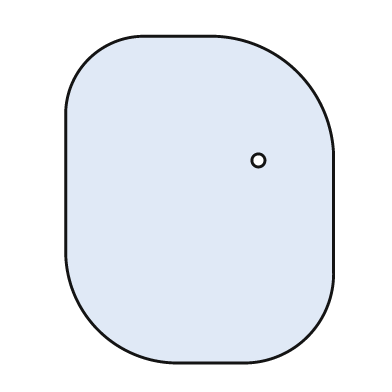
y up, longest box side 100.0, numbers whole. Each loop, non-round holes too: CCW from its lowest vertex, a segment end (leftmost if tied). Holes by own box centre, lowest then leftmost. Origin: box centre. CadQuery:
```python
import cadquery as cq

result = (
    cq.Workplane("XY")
    .moveTo(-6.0, -50.0)
    .lineTo(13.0, -50.0)
    .threePointArc((33.0, -42.0), (41.0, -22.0))
    .lineTo(41.0, 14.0)
    .threePointArc((30.0, 39.0), (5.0, 50.0))
    .lineTo(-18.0, 50.0)
    .threePointArc((-34.0, 43.0), (-41.0, 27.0))
    .lineTo(-41.0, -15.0)
    .threePointArc((-31.0, -40.0), (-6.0, -50.0))
    .close()
    .moveTo(18.0, 12.0)
    .circle(2.0)
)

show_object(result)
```